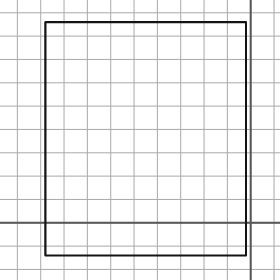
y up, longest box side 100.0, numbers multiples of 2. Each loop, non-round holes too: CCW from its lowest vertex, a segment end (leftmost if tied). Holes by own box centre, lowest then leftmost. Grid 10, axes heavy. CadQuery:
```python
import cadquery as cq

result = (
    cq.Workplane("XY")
    .moveTo(-88.0, -14.0)
    .lineTo(-2.0, -14.0)
    .lineTo(-2.0, 86.0)
    .lineTo(-88.0, 86.0)
    .close()
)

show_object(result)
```